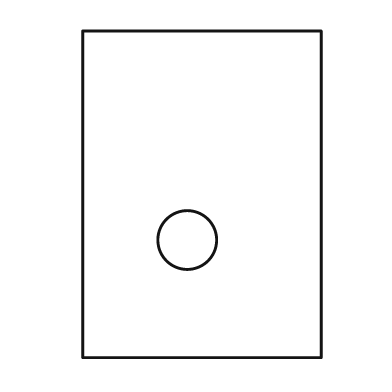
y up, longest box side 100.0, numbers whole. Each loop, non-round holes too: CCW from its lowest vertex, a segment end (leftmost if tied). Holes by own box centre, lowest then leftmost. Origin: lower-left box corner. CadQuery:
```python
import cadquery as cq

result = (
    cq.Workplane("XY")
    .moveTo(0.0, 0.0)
    .lineTo(73.0, 0.0)
    .lineTo(73.0, 100.0)
    .lineTo(0.0, 100.0)
    .close()
    .moveTo(32.0, 36.0)
    .circle(9.0)
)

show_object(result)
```